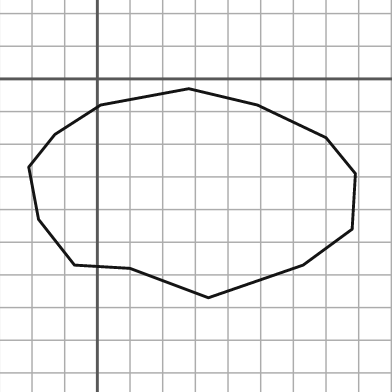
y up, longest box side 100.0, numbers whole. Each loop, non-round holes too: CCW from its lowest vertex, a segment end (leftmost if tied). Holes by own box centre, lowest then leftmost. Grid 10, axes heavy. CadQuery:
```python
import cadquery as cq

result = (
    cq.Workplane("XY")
    .moveTo(34.0, -67.0)
    .lineTo(63.0, -57.0)
    .lineTo(78.0, -46.0)
    .lineTo(79.0, -29.0)
    .lineTo(70.0, -18.0)
    .lineTo(49.0, -8.0)
    .lineTo(28.0, -3.0)
    .lineTo(1.0, -8.0)
    .lineTo(-13.0, -17.0)
    .lineTo(-21.0, -27.0)
    .lineTo(-18.0, -43.0)
    .lineTo(-7.0, -57.0)
    .lineTo(10.0, -58.0)
    .close()
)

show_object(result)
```